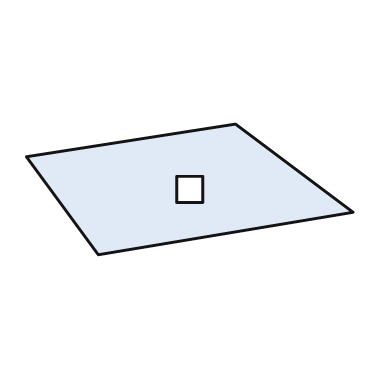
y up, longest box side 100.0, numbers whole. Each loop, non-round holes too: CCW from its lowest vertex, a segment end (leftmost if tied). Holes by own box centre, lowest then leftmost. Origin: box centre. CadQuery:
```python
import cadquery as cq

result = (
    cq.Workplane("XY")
    .moveTo(-28.0, -20.0)
    .lineTo(50.0, -7.0)
    .lineTo(14.0, 20.0)
    .lineTo(-50.0, 10.0)
    .close()
    .moveTo(-4.0, -4.0)
    .lineTo(4.0, -4.0)
    .lineTo(4.0, 4.0)
    .lineTo(-4.0, 4.0)
    .close()
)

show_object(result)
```